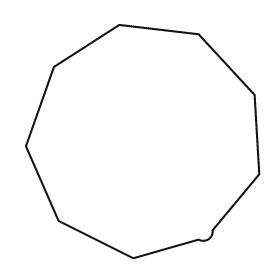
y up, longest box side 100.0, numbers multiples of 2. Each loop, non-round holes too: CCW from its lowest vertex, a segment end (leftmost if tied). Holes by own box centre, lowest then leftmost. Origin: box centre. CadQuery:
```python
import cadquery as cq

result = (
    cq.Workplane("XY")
    .moveTo(-4.0, -50.0)
    .lineTo(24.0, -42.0)
    .threePointArc((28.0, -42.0), (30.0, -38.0))
    .lineTo(50.0, -14.0)
    .lineTo(48.0, 20.0)
    .lineTo(24.0, 46.0)
    .lineTo(-10.0, 50.0)
    .lineTo(-38.0, 32.0)
    .lineTo(-50.0, -2.0)
    .lineTo(-36.0, -34.0)
    .close()
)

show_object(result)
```